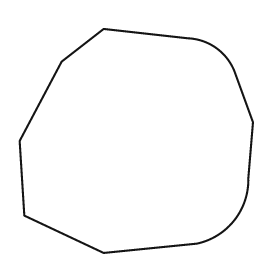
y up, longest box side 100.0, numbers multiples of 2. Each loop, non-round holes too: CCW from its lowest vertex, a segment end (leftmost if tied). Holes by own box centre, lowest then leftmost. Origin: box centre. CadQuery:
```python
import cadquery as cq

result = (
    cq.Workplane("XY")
    .moveTo(-14.0, -48.0)
    .lineTo(26.0, -44.0)
    .threePointArc((42.0, -34.0), (48.0, -16.0))
    .lineTo(50.0, 8.0)
    .lineTo(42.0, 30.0)
    .threePointArc((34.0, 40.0), (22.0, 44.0))
    .lineTo(-14.0, 48.0)
    .lineTo(-32.0, 34.0)
    .lineTo(-50.0, 0.0)
    .lineTo(-48.0, -32.0)
    .close()
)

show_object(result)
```